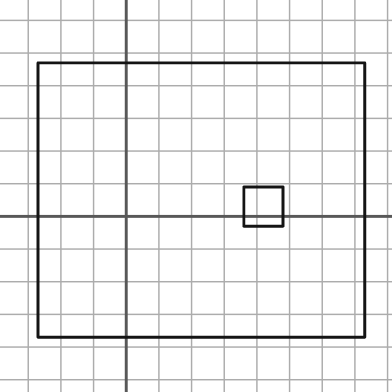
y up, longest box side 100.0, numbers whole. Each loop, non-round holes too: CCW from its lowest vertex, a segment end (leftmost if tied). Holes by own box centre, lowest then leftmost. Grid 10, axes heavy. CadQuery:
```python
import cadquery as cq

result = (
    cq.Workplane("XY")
    .moveTo(-27.0, -37.0)
    .lineTo(73.0, -37.0)
    .lineTo(73.0, 47.0)
    .lineTo(-27.0, 47.0)
    .close()
    .moveTo(36.0, -3.0)
    .lineTo(48.0, -3.0)
    .lineTo(48.0, 9.0)
    .lineTo(36.0, 9.0)
    .close()
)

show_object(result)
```